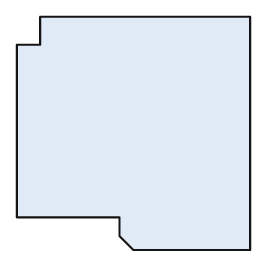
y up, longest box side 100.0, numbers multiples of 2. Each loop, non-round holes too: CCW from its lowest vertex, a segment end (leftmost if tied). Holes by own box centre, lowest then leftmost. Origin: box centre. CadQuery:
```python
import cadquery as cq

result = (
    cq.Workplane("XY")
    .moveTo(0.0, -50.0)
    .lineTo(50.0, -50.0)
    .lineTo(50.0, 50.0)
    .lineTo(-40.0, 50.0)
    .lineTo(-40.0, 38.0)
    .lineTo(-50.0, 38.0)
    .lineTo(-50.0, -36.0)
    .lineTo(-6.0, -36.0)
    .lineTo(-6.0, -44.0)
    .close()
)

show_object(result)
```